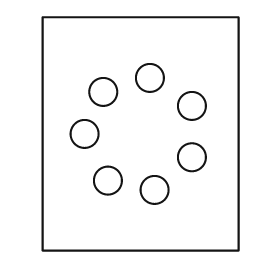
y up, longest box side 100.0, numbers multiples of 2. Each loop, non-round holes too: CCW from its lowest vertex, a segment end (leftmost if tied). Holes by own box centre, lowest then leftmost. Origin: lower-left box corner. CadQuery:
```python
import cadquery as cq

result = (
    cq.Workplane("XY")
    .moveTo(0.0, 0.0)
    .lineTo(84.0, 0.0)
    .lineTo(84.0, 100.0)
    .lineTo(0.0, 100.0)
    .close()
    .moveTo(48.0, 26.0)
    .circle(6.0)
    .moveTo(28.0, 30.0)
    .circle(6.0)
    .moveTo(64.0, 40.0)
    .circle(6.0)
    .moveTo(18.0, 50.0)
    .circle(6.0)
    .moveTo(64.0, 62.0)
    .circle(6.0)
    .moveTo(26.0, 68.0)
    .circle(6.0)
    .moveTo(46.0, 74.0)
    .circle(6.0)
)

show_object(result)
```